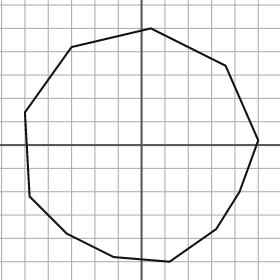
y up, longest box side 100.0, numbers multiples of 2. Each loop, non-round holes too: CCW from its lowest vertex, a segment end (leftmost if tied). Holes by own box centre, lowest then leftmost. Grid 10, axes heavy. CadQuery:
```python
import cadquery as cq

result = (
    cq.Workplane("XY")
    .moveTo(12.0, -50.0)
    .lineTo(32.0, -36.0)
    .lineTo(42.0, -20.0)
    .lineTo(50.0, 2.0)
    .lineTo(36.0, 34.0)
    .lineTo(4.0, 50.0)
    .lineTo(-30.0, 42.0)
    .lineTo(-50.0, 14.0)
    .lineTo(-48.0, -22.0)
    .lineTo(-32.0, -38.0)
    .lineTo(-12.0, -48.0)
    .close()
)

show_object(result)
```